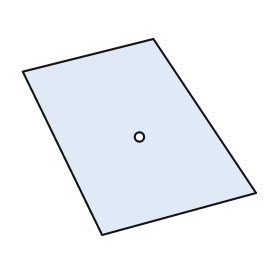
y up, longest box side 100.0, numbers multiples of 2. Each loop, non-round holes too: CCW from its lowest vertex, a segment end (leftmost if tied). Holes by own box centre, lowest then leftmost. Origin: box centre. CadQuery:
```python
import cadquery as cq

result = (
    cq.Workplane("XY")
    .moveTo(-16.0, -42.0)
    .lineTo(50.0, -24.0)
    .lineTo(6.0, 42.0)
    .lineTo(-50.0, 28.0)
    .close()
    .moveTo(0.0, 0.0)
    .circle(2.0)
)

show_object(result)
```